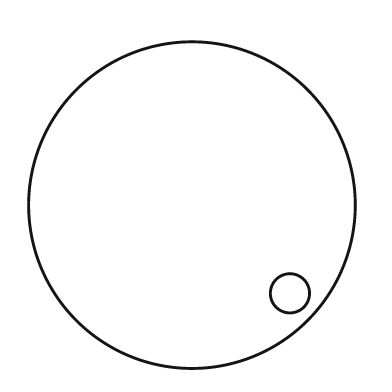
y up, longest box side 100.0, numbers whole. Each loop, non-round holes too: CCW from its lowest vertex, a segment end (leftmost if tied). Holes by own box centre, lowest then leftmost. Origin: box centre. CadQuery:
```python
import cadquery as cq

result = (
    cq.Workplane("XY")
    .moveTo(0.0, 0.0)
    .circle(50.0)
    .moveTo(30.0, -27.0)
    .circle(6.0)
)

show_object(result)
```